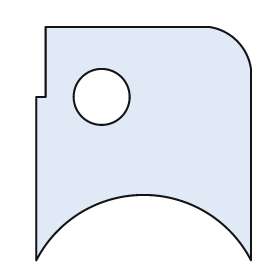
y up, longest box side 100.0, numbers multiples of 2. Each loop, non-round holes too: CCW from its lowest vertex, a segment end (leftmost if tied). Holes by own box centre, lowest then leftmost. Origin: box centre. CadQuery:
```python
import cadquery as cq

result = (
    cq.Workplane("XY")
    .moveTo(-46.0, -50.0)
    .threePointArc((0.0, -22.0), (46.0, -50.0))
    .lineTo(46.0, 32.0)
    .threePointArc((40.0, 44.0), (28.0, 50.0))
    .lineTo(-42.0, 50.0)
    .lineTo(-42.0, 20.0)
    .lineTo(-46.0, 20.0)
    .close()
    .moveTo(-18.0, 20.0)
    .circle(12.0)
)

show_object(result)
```